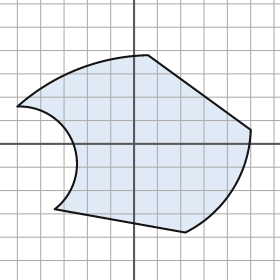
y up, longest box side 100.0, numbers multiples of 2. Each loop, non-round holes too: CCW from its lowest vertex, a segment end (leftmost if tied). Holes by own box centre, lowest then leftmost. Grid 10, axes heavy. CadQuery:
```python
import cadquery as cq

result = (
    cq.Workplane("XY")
    .moveTo(22.0, -38.0)
    .threePointArc((42.0, -20.0), (50.0, 6.0))
    .lineTo(6.0, 38.0)
    .threePointArc((-24.0, 32.0), (-50.0, 16.0))
    .threePointArc((-26.0, 0.0), (-34.0, -28.0))
    .close()
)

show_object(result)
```